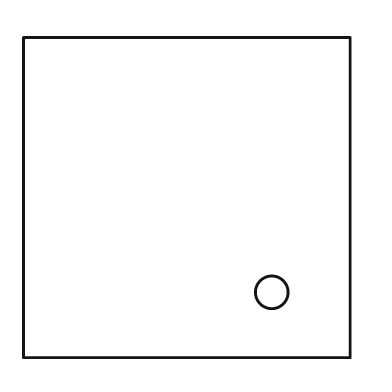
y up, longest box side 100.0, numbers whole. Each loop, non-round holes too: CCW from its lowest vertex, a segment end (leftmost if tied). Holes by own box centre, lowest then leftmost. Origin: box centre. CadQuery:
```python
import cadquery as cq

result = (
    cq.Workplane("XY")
    .moveTo(-50.0, -49.0)
    .lineTo(50.0, -49.0)
    .lineTo(50.0, 49.0)
    .lineTo(-50.0, 49.0)
    .close()
    .moveTo(26.0, -29.0)
    .circle(5.0)
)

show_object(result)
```